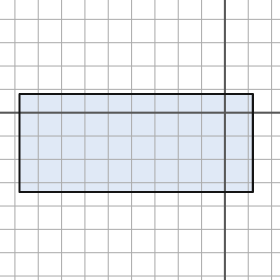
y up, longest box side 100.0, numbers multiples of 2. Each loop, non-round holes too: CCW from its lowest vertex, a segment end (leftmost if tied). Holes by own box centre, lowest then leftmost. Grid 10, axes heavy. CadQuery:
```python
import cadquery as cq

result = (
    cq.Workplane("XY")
    .moveTo(-88.0, -34.0)
    .lineTo(12.0, -34.0)
    .lineTo(12.0, 8.0)
    .lineTo(-88.0, 8.0)
    .close()
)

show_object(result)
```